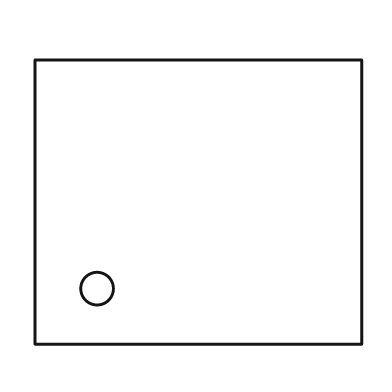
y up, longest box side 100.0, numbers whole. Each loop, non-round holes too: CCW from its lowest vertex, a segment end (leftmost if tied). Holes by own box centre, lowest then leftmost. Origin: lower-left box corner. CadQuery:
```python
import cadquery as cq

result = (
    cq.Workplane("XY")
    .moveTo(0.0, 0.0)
    .lineTo(100.0, 0.0)
    .lineTo(100.0, 87.0)
    .lineTo(0.0, 87.0)
    .close()
    .moveTo(19.0, 17.0)
    .circle(5.0)
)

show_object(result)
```